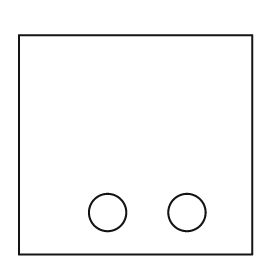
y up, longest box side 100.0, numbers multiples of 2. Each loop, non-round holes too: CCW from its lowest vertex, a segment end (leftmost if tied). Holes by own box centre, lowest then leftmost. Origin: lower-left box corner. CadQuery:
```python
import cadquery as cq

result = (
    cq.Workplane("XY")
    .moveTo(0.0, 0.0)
    .lineTo(100.0, 0.0)
    .lineTo(100.0, 94.0)
    .lineTo(0.0, 94.0)
    .close()
    .moveTo(38.0, 18.0)
    .circle(8.0)
    .moveTo(72.0, 18.0)
    .circle(8.0)
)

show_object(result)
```